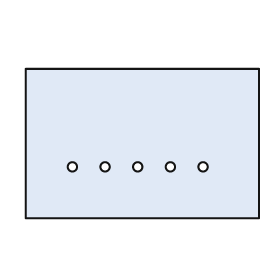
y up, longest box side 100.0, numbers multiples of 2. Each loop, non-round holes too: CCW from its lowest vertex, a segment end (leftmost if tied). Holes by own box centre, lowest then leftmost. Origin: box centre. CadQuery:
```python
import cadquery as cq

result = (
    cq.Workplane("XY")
    .moveTo(-50.0, -32.0)
    .lineTo(50.0, -32.0)
    .lineTo(50.0, 32.0)
    .lineTo(-50.0, 32.0)
    .close()
    .moveTo(-30.0, -10.0)
    .circle(2.0)
    .moveTo(-16.0, -10.0)
    .circle(2.0)
    .moveTo(-2.0, -10.0)
    .circle(2.0)
    .moveTo(12.0, -10.0)
    .circle(2.0)
    .moveTo(26.0, -10.0)
    .circle(2.0)
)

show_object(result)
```